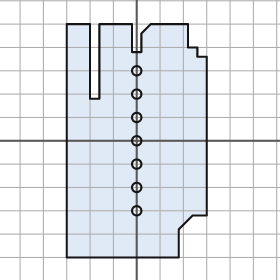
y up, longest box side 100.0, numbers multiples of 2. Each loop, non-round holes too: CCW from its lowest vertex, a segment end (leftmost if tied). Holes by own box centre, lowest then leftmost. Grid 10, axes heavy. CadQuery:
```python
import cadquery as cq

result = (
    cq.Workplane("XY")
    .moveTo(-30.0, -50.0)
    .lineTo(18.0, -50.0)
    .lineTo(18.0, -38.0)
    .lineTo(24.0, -32.0)
    .lineTo(30.0, -32.0)
    .lineTo(30.0, 36.0)
    .lineTo(26.0, 36.0)
    .lineTo(26.0, 40.0)
    .lineTo(22.0, 40.0)
    .lineTo(22.0, 50.0)
    .lineTo(6.0, 50.0)
    .lineTo(2.0, 46.0)
    .lineTo(2.0, 38.0)
    .lineTo(-2.0, 38.0)
    .lineTo(-2.0, 50.0)
    .lineTo(-16.0, 50.0)
    .lineTo(-16.0, 18.0)
    .lineTo(-20.0, 18.0)
    .lineTo(-20.0, 50.0)
    .lineTo(-30.0, 50.0)
    .close()
    .moveTo(0.0, -30.0)
    .circle(2.0)
    .moveTo(0.0, -20.0)
    .circle(2.0)
    .moveTo(0.0, -10.0)
    .circle(2.0)
    .moveTo(0.0, 0.0)
    .circle(2.0)
    .moveTo(0.0, 10.0)
    .circle(2.0)
    .moveTo(0.0, 20.0)
    .circle(2.0)
    .moveTo(0.0, 30.0)
    .circle(2.0)
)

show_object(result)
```